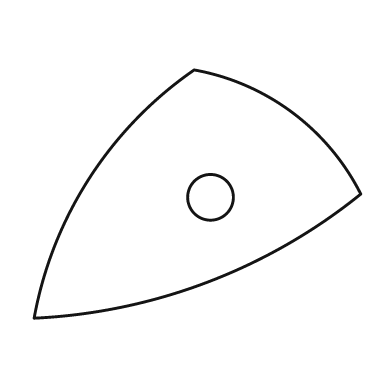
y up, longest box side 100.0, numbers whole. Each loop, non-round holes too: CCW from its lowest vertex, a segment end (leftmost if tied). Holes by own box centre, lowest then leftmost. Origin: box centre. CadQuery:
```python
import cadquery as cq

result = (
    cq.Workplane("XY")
    .moveTo(-50.0, -38.0)
    .threePointArc((3.0, -27.0), (50.0, 0.0))
    .threePointArc((29.0, 25.0), (-1.0, 38.0))
    .threePointArc((-33.0, 5.0), (-50.0, -38.0))
    .close()
    .moveTo(4.0, -1.0)
    .circle(7.0)
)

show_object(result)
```